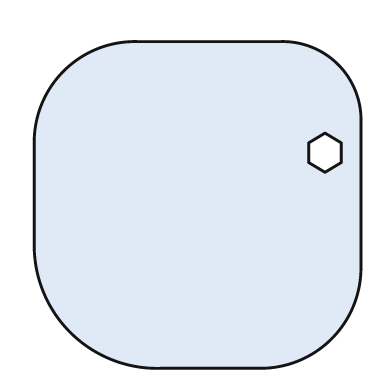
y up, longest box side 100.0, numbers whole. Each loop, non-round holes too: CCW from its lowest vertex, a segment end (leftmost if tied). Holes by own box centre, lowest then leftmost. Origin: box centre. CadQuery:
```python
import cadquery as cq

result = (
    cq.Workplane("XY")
    .moveTo(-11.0, -50.0)
    .lineTo(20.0, -50.0)
    .threePointArc((41.0, -41.0), (50.0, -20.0))
    .lineTo(50.0, 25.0)
    .threePointArc((43.0, 43.0), (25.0, 50.0))
    .lineTo(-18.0, 50.0)
    .threePointArc((-41.0, 41.0), (-50.0, 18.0))
    .lineTo(-50.0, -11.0)
    .threePointArc((-39.0, -39.0), (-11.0, -50.0))
    .close()
    .moveTo(39.0, 10.0)
    .lineTo(44.0, 13.0)
    .lineTo(44.0, 19.0)
    .lineTo(39.0, 22.0)
    .lineTo(34.0, 19.0)
    .lineTo(34.0, 13.0)
    .close()
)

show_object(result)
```